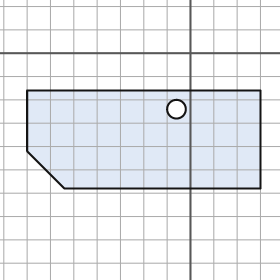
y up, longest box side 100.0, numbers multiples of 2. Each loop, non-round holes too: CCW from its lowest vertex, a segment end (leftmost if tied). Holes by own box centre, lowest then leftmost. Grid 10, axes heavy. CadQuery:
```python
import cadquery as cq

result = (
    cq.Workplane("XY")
    .moveTo(-54.0, -58.0)
    .lineTo(30.0, -58.0)
    .lineTo(30.0, -16.0)
    .lineTo(-70.0, -16.0)
    .lineTo(-70.0, -42.0)
    .close()
    .moveTo(-6.0, -24.0)
    .circle(4.0)
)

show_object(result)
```